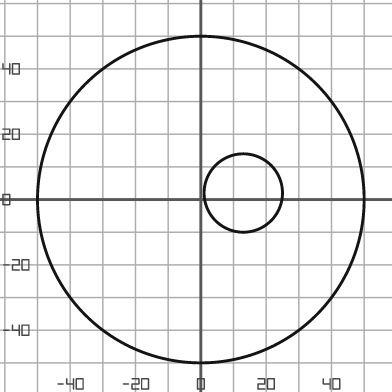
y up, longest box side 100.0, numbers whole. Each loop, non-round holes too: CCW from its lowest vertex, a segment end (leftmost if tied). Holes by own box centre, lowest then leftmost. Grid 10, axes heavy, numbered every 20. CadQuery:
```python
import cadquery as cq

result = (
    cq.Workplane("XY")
    .moveTo(0.0, 0.0)
    .circle(50.0)
    .moveTo(13.0, 2.0)
    .circle(12.0)
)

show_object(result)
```